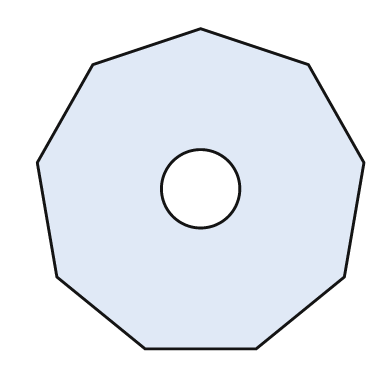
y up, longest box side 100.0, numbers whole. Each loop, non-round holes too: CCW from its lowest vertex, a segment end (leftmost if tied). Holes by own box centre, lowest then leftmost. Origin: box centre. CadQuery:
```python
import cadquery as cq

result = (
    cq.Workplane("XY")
    .moveTo(-17.0, -49.0)
    .lineTo(17.0, -49.0)
    .lineTo(44.0, -27.0)
    .lineTo(50.0, 8.0)
    .lineTo(33.0, 38.0)
    .lineTo(0.0, 49.0)
    .lineTo(-33.0, 38.0)
    .lineTo(-50.0, 8.0)
    .lineTo(-44.0, -27.0)
    .close()
    .moveTo(0.0, 0.0)
    .circle(12.0)
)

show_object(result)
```